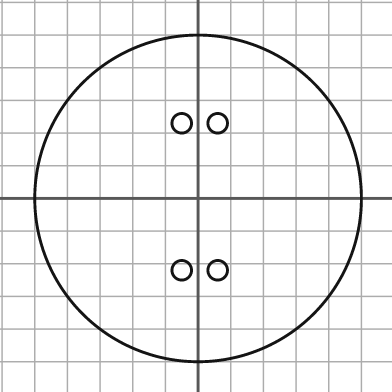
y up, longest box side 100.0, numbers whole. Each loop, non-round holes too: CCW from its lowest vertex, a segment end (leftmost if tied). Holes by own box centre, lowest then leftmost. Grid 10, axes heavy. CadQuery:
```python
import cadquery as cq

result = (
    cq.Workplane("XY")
    .moveTo(0.0, 0.0)
    .circle(50.0)
    .moveTo(-5.0, -22.0)
    .circle(3.0)
    .moveTo(6.0, -22.0)
    .circle(3.0)
    .moveTo(-5.0, 23.0)
    .circle(3.0)
    .moveTo(6.0, 23.0)
    .circle(3.0)
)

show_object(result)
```